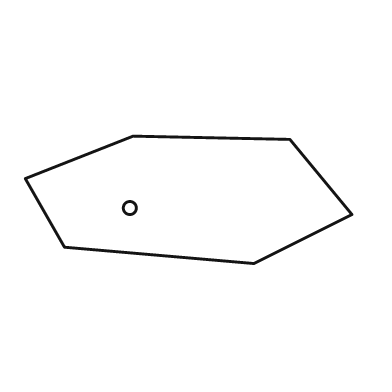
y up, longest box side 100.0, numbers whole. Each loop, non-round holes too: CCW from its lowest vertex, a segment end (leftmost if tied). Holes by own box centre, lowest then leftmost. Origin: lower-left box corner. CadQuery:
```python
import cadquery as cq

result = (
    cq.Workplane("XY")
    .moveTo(70.0, 0.0)
    .lineTo(100.0, 15.0)
    .lineTo(81.0, 38.0)
    .lineTo(33.0, 39.0)
    .lineTo(0.0, 26.0)
    .lineTo(12.0, 5.0)
    .close()
    .moveTo(32.0, 17.0)
    .circle(2.0)
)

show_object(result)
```